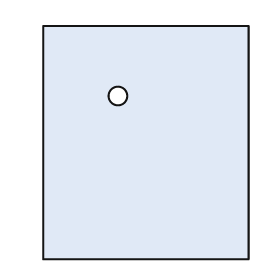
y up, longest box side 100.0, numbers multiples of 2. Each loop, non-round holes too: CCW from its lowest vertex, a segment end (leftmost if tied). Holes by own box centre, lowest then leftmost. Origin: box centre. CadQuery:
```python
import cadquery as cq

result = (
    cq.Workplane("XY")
    .moveTo(-44.0, -50.0)
    .lineTo(44.0, -50.0)
    .lineTo(44.0, 50.0)
    .lineTo(-44.0, 50.0)
    .close()
    .moveTo(-12.0, 20.0)
    .circle(4.0)
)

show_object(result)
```